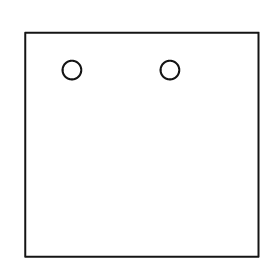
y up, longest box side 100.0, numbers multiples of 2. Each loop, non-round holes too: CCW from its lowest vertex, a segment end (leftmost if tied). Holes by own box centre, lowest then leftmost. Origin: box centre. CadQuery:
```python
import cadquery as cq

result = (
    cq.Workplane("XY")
    .moveTo(-50.0, -48.0)
    .lineTo(50.0, -48.0)
    .lineTo(50.0, 48.0)
    .lineTo(-50.0, 48.0)
    .close()
    .moveTo(-30.0, 32.0)
    .circle(4.0)
    .moveTo(12.0, 32.0)
    .circle(4.0)
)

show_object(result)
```